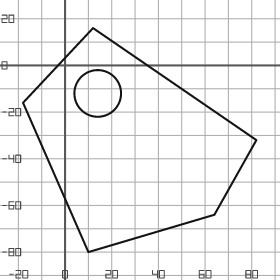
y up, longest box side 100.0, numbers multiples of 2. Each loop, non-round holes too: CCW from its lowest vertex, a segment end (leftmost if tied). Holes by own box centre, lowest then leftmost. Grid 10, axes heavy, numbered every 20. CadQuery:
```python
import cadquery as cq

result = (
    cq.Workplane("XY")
    .moveTo(10.0, -80.0)
    .lineTo(64.0, -64.0)
    .lineTo(82.0, -32.0)
    .lineTo(12.0, 16.0)
    .lineTo(-18.0, -16.0)
    .close()
    .moveTo(14.0, -12.0)
    .circle(10.0)
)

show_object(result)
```